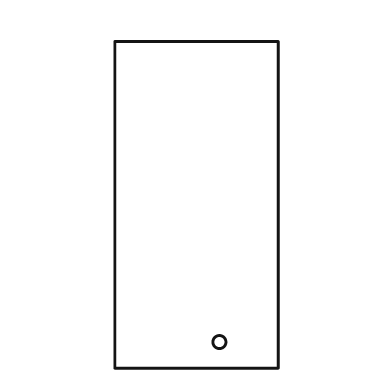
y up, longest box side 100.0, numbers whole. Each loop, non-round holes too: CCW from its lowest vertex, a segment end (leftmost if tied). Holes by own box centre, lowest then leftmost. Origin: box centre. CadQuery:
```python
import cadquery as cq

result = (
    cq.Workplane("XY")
    .moveTo(-25.0, -50.0)
    .lineTo(25.0, -50.0)
    .lineTo(25.0, 50.0)
    .lineTo(-25.0, 50.0)
    .close()
    .moveTo(7.0, -42.0)
    .circle(2.0)
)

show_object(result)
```